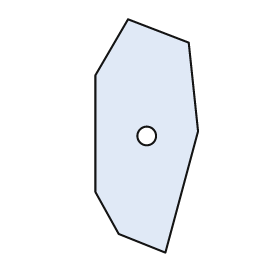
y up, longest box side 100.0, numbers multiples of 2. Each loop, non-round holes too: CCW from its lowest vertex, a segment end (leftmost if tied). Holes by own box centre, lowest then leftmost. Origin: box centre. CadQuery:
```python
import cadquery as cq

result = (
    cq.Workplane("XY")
    .moveTo(8.0, -50.0)
    .lineTo(22.0, 2.0)
    .lineTo(18.0, 40.0)
    .lineTo(-8.0, 50.0)
    .lineTo(-22.0, 26.0)
    .lineTo(-22.0, -24.0)
    .lineTo(-12.0, -42.0)
    .close()
    .moveTo(0.0, 0.0)
    .circle(4.0)
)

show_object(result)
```